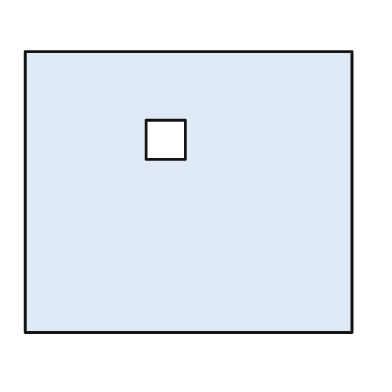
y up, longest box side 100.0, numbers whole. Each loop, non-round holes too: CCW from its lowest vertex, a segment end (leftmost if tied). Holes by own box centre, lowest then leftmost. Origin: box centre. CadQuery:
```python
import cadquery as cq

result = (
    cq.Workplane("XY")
    .moveTo(-50.0, -43.0)
    .lineTo(50.0, -43.0)
    .lineTo(50.0, 43.0)
    .lineTo(-50.0, 43.0)
    .close()
    .moveTo(-13.0, 10.0)
    .lineTo(-1.0, 10.0)
    .lineTo(-1.0, 22.0)
    .lineTo(-13.0, 22.0)
    .close()
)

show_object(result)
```